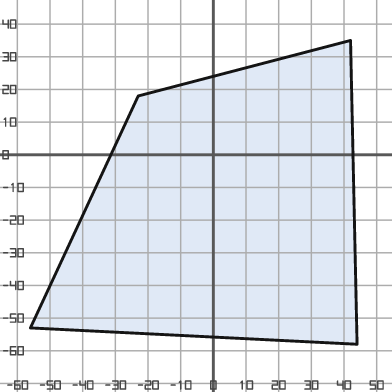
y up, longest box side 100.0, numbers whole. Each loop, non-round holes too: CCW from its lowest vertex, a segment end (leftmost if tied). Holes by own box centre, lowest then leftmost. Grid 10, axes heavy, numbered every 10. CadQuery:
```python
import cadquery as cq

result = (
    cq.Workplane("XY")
    .moveTo(44.0, -58.0)
    .lineTo(42.0, 35.0)
    .lineTo(-23.0, 18.0)
    .lineTo(-56.0, -53.0)
    .close()
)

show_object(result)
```